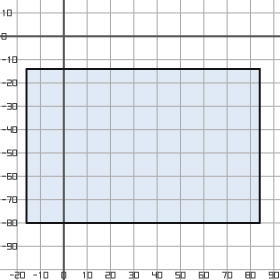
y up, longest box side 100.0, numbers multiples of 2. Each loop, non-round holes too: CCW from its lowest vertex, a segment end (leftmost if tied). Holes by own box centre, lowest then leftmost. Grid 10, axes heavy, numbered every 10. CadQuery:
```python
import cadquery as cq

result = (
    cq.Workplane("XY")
    .moveTo(-16.0, -80.0)
    .lineTo(84.0, -80.0)
    .lineTo(84.0, -14.0)
    .lineTo(-16.0, -14.0)
    .close()
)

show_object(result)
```